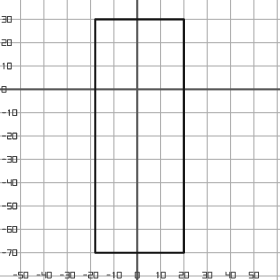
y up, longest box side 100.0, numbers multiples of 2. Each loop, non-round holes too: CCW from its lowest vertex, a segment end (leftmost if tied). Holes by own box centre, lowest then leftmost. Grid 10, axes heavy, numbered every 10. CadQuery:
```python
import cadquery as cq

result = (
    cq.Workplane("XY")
    .moveTo(-18.0, -70.0)
    .lineTo(20.0, -70.0)
    .lineTo(20.0, 30.0)
    .lineTo(-18.0, 30.0)
    .close()
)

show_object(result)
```